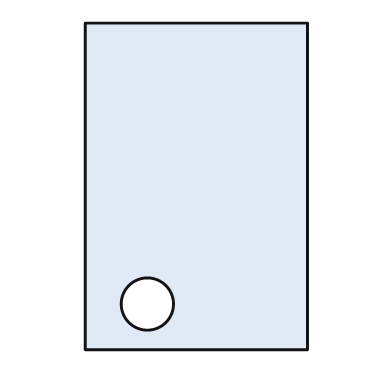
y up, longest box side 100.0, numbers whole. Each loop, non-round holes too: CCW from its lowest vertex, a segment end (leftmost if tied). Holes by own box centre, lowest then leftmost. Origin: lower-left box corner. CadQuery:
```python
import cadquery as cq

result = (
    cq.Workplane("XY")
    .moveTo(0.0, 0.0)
    .lineTo(68.0, 0.0)
    .lineTo(68.0, 100.0)
    .lineTo(0.0, 100.0)
    .close()
    .moveTo(19.0, 14.0)
    .circle(8.0)
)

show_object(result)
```